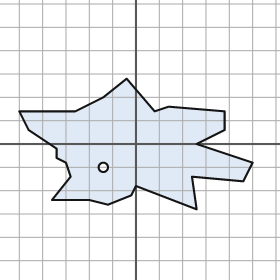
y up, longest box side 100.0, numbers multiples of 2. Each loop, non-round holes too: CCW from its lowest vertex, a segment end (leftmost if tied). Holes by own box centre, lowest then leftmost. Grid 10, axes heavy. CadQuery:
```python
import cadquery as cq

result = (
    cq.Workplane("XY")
    .moveTo(26.0, -28.0)
    .lineTo(24.0, -14.0)
    .lineTo(46.0, -16.0)
    .lineTo(50.0, -8.0)
    .lineTo(26.0, 0.0)
    .lineTo(38.0, 6.0)
    .lineTo(38.0, 14.0)
    .lineTo(14.0, 16.0)
    .lineTo(8.0, 14.0)
    .lineTo(-4.0, 28.0)
    .lineTo(-14.0, 20.0)
    .lineTo(-26.0, 14.0)
    .lineTo(-50.0, 14.0)
    .lineTo(-46.0, 6.0)
    .lineTo(-34.0, -2.0)
    .lineTo(-34.0, -6.0)
    .lineTo(-30.0, -8.0)
    .lineTo(-28.0, -14.0)
    .lineTo(-36.0, -24.0)
    .lineTo(-20.0, -24.0)
    .lineTo(-12.0, -26.0)
    .lineTo(-2.0, -22.0)
    .lineTo(0.0, -18.0)
    .close()
    .moveTo(-14.0, -10.0)
    .circle(2.0)
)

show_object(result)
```